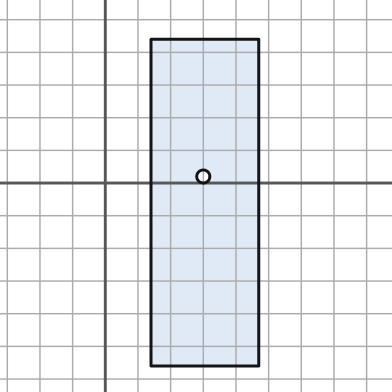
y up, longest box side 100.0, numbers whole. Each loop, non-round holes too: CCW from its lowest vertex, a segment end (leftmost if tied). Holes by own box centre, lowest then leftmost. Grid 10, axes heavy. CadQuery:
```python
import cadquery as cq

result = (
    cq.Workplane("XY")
    .moveTo(14.0, -56.0)
    .lineTo(47.0, -56.0)
    .lineTo(47.0, 44.0)
    .lineTo(14.0, 44.0)
    .close()
    .moveTo(30.0, 2.0)
    .circle(2.0)
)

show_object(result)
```